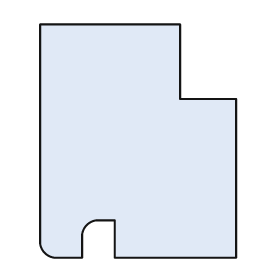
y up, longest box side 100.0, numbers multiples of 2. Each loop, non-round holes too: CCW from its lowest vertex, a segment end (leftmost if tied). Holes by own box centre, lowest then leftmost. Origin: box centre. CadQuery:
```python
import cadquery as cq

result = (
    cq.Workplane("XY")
    .moveTo(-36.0, -50.0)
    .lineTo(-24.0, -50.0)
    .lineTo(-24.0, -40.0)
    .threePointArc((-22.0, -36.0), (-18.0, -34.0))
    .lineTo(-10.0, -34.0)
    .lineTo(-10.0, -50.0)
    .lineTo(42.0, -50.0)
    .lineTo(42.0, 18.0)
    .lineTo(18.0, 18.0)
    .lineTo(18.0, 50.0)
    .lineTo(-42.0, 50.0)
    .lineTo(-42.0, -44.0)
    .threePointArc((-40.0, -48.0), (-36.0, -50.0))
    .close()
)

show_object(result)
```